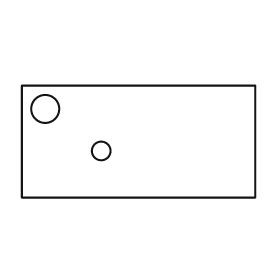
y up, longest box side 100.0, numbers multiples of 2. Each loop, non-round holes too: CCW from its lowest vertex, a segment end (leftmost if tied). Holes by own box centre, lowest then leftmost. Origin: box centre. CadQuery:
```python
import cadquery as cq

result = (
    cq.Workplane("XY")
    .moveTo(-50.0, -24.0)
    .lineTo(50.0, -24.0)
    .lineTo(50.0, 24.0)
    .lineTo(-50.0, 24.0)
    .close()
    .moveTo(-16.0, -4.0)
    .circle(4.0)
    .moveTo(-40.0, 14.0)
    .circle(6.0)
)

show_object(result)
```